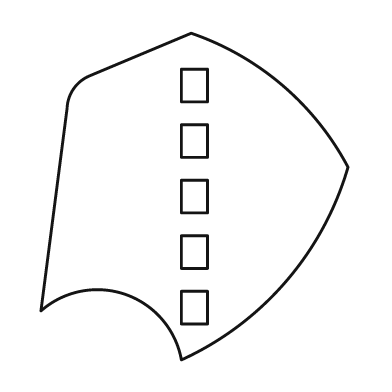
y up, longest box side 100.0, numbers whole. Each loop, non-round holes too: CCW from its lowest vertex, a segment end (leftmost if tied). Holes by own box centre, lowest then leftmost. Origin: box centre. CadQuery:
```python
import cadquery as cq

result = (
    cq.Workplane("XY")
    .moveTo(-4.0, -50.0)
    .threePointArc((28.0, -26.0), (47.0, 9.0))
    .threePointArc((27.0, 34.0), (-1.0, 50.0))
    .lineTo(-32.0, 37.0)
    .threePointArc((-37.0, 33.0), (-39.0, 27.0))
    .lineTo(-47.0, -35.0)
    .threePointArc((-21.0, -30.0), (-4.0, -50.0))
    .close()
    .moveTo(-4.0, -39.0)
    .lineTo(4.0, -39.0)
    .lineTo(4.0, -29.0)
    .lineTo(-4.0, -29.0)
    .close()
    .moveTo(-4.0, -22.0)
    .lineTo(4.0, -22.0)
    .lineTo(4.0, -12.0)
    .lineTo(-4.0, -12.0)
    .close()
    .moveTo(-4.0, -5.0)
    .lineTo(4.0, -5.0)
    .lineTo(4.0, 5.0)
    .lineTo(-4.0, 5.0)
    .close()
    .moveTo(-4.0, 12.0)
    .lineTo(4.0, 12.0)
    .lineTo(4.0, 22.0)
    .lineTo(-4.0, 22.0)
    .close()
    .moveTo(-4.0, 29.0)
    .lineTo(4.0, 29.0)
    .lineTo(4.0, 39.0)
    .lineTo(-4.0, 39.0)
    .close()
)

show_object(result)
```